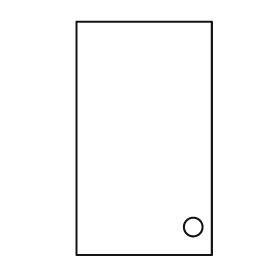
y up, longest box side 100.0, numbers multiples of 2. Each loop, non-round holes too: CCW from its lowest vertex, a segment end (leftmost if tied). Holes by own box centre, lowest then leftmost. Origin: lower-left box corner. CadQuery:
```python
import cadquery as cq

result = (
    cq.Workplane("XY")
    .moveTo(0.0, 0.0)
    .lineTo(58.0, 0.0)
    .lineTo(58.0, 100.0)
    .lineTo(0.0, 100.0)
    .close()
    .moveTo(50.0, 12.0)
    .circle(4.0)
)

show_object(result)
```